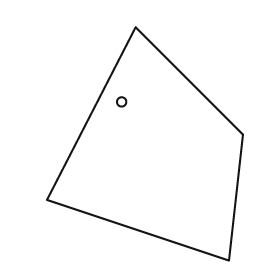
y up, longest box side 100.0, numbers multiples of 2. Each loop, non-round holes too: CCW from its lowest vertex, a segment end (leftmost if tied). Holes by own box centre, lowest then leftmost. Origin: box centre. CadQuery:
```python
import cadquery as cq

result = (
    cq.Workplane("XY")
    .moveTo(36.0, -50.0)
    .lineTo(42.0, 4.0)
    .lineTo(-4.0, 50.0)
    .lineTo(-42.0, -24.0)
    .close()
    .moveTo(-10.0, 18.0)
    .circle(2.0)
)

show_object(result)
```